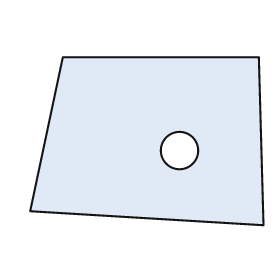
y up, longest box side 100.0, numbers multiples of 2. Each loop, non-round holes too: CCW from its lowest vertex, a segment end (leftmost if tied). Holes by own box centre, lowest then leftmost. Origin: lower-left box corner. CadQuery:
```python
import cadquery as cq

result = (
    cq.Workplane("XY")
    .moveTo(100.0, 0.0)
    .lineTo(98.0, 72.0)
    .lineTo(14.0, 72.0)
    .lineTo(0.0, 6.0)
    .close()
    .moveTo(64.0, 32.0)
    .circle(8.0)
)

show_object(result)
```